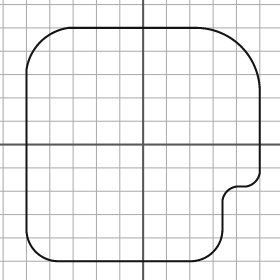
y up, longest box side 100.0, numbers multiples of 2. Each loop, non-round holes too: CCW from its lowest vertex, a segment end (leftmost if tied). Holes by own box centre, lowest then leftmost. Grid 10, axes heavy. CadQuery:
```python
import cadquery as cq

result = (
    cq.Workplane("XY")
    .moveTo(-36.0, -50.0)
    .lineTo(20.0, -50.0)
    .threePointArc((30.0, -46.0), (34.0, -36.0))
    .lineTo(34.0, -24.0)
    .threePointArc((36.0, -20.0), (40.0, -18.0))
    .lineTo(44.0, -18.0)
    .threePointArc((48.0, -16.0), (50.0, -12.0))
    .lineTo(50.0, 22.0)
    .threePointArc((42.0, 42.0), (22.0, 50.0))
    .lineTo(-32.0, 50.0)
    .threePointArc((-44.0, 44.0), (-50.0, 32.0))
    .lineTo(-50.0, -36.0)
    .threePointArc((-46.0, -46.0), (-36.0, -50.0))
    .close()
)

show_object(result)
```